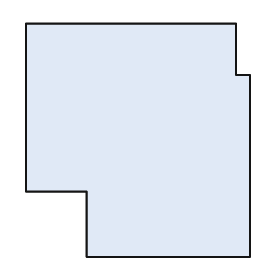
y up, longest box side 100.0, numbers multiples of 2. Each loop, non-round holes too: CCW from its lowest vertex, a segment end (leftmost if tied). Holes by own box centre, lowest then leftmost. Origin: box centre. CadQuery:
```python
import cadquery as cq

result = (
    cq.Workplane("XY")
    .moveTo(-22.0, -50.0)
    .lineTo(48.0, -50.0)
    .lineTo(48.0, 28.0)
    .lineTo(42.0, 28.0)
    .lineTo(42.0, 50.0)
    .lineTo(-48.0, 50.0)
    .lineTo(-48.0, -22.0)
    .lineTo(-22.0, -22.0)
    .close()
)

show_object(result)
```